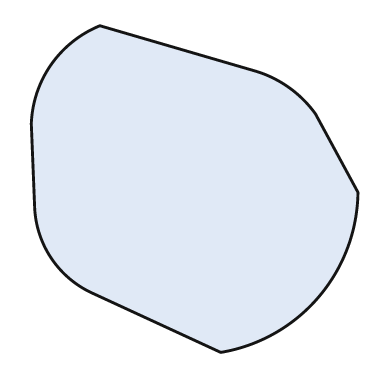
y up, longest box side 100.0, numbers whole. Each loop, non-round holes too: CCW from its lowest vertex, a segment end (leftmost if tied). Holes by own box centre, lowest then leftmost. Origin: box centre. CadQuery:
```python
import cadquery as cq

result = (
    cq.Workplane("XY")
    .moveTo(8.0, -50.0)
    .threePointArc((38.0, -33.0), (50.0, -1.0))
    .lineTo(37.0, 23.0)
    .threePointArc((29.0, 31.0), (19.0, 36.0))
    .lineTo(-29.0, 50.0)
    .threePointArc((-44.0, 38.0), (-50.0, 20.0))
    .lineTo(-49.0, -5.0)
    .threePointArc((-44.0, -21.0), (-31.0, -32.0))
    .close()
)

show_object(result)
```